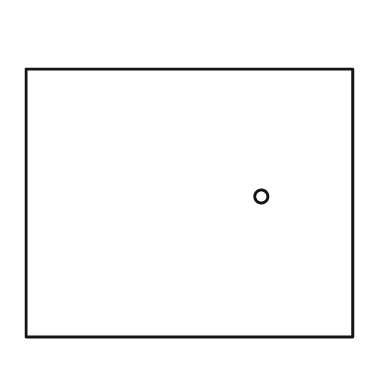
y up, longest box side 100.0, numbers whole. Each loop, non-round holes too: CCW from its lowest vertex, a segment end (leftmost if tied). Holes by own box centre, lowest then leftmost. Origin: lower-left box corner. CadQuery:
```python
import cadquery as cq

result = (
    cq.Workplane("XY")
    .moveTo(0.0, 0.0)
    .lineTo(100.0, 0.0)
    .lineTo(100.0, 82.0)
    .lineTo(0.0, 82.0)
    .close()
    .moveTo(72.0, 43.0)
    .circle(2.0)
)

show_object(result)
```